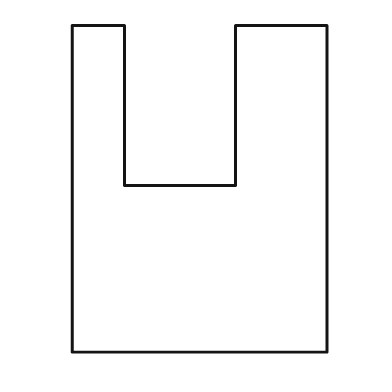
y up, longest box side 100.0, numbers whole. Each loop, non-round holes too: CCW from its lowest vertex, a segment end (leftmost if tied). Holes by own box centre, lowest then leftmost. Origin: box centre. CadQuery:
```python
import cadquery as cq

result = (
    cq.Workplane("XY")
    .moveTo(-39.0, -50.0)
    .lineTo(39.0, -50.0)
    .lineTo(39.0, 50.0)
    .lineTo(11.0, 50.0)
    .lineTo(11.0, 1.0)
    .lineTo(-23.0, 1.0)
    .lineTo(-23.0, 50.0)
    .lineTo(-39.0, 50.0)
    .close()
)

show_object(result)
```